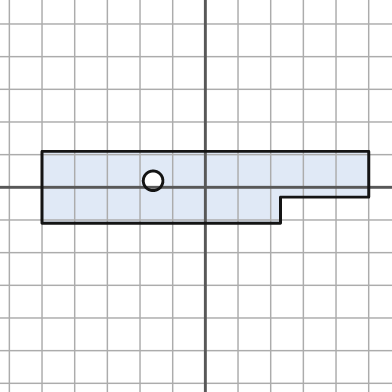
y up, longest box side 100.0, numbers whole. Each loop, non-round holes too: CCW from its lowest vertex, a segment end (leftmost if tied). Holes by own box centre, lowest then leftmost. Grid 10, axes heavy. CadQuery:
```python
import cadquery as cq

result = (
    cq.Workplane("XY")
    .moveTo(-50.0, -11.0)
    .lineTo(23.0, -11.0)
    .lineTo(23.0, -3.0)
    .lineTo(50.0, -3.0)
    .lineTo(50.0, 11.0)
    .lineTo(-50.0, 11.0)
    .close()
    .moveTo(-16.0, 2.0)
    .circle(3.0)
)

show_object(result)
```